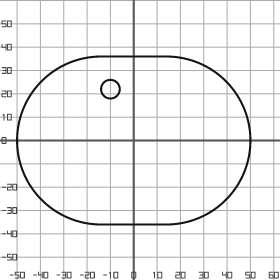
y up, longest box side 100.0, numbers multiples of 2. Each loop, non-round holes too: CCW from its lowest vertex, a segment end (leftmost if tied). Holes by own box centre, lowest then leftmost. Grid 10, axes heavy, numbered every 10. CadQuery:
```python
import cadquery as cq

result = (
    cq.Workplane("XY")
    .moveTo(-14.0, -36.0)
    .lineTo(14.0, -36.0)
    .threePointArc((50.0, 0.0), (14.0, 36.0))
    .lineTo(-14.0, 36.0)
    .threePointArc((-50.0, 0.0), (-14.0, -36.0))
    .close()
    .moveTo(-10.0, 22.0)
    .circle(4.0)
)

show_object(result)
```